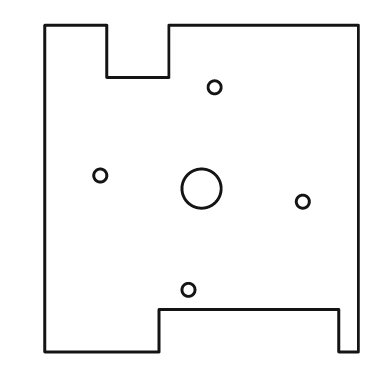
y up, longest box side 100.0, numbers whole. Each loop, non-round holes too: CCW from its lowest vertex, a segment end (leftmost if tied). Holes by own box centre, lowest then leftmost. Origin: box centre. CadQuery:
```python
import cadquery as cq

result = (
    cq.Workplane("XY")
    .moveTo(-48.0, -50.0)
    .lineTo(-13.0, -50.0)
    .lineTo(-13.0, -37.0)
    .lineTo(42.0, -37.0)
    .lineTo(42.0, -50.0)
    .lineTo(48.0, -50.0)
    .lineTo(48.0, 50.0)
    .lineTo(-10.0, 50.0)
    .lineTo(-10.0, 34.0)
    .lineTo(-29.0, 34.0)
    .lineTo(-29.0, 50.0)
    .lineTo(-48.0, 50.0)
    .close()
    .moveTo(-4.0, -31.0)
    .circle(2.0)
    .moveTo(31.0, -4.0)
    .circle(2.0)
    .moveTo(0.0, 0.0)
    .circle(6.0)
    .moveTo(-31.0, 4.0)
    .circle(2.0)
    .moveTo(4.0, 31.0)
    .circle(2.0)
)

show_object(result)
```